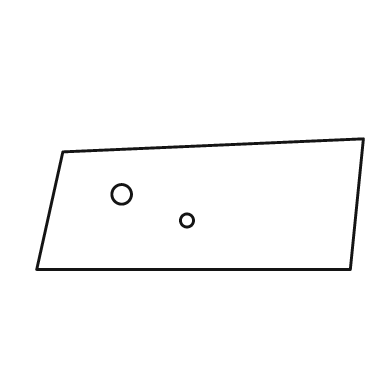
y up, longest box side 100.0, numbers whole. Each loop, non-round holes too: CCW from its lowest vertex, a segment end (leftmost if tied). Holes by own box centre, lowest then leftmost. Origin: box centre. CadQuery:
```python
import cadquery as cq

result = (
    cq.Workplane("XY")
    .moveTo(-50.0, -20.0)
    .lineTo(46.0, -20.0)
    .lineTo(50.0, 20.0)
    .lineTo(-42.0, 16.0)
    .close()
    .moveTo(-4.0, -5.0)
    .circle(2.0)
    .moveTo(-24.0, 3.0)
    .circle(3.0)
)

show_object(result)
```